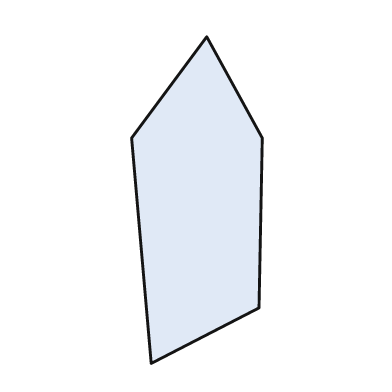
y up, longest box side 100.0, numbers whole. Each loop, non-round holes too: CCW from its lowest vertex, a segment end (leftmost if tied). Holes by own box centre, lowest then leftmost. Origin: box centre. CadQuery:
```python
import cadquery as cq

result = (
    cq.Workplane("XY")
    .moveTo(-14.0, -50.0)
    .lineTo(19.0, -33.0)
    .lineTo(20.0, 19.0)
    .lineTo(3.0, 50.0)
    .lineTo(-20.0, 19.0)
    .close()
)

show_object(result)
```